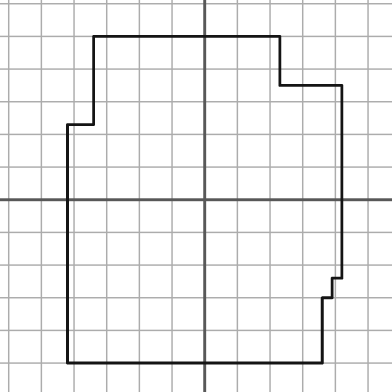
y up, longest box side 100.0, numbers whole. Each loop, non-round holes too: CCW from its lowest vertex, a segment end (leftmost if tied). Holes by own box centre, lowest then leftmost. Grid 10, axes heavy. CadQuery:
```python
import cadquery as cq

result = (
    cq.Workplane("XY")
    .moveTo(-42.0, -50.0)
    .lineTo(36.0, -50.0)
    .lineTo(36.0, -30.0)
    .lineTo(39.0, -30.0)
    .lineTo(39.0, -24.0)
    .lineTo(42.0, -24.0)
    .lineTo(42.0, 35.0)
    .lineTo(23.0, 35.0)
    .lineTo(23.0, 50.0)
    .lineTo(-34.0, 50.0)
    .lineTo(-34.0, 23.0)
    .lineTo(-42.0, 23.0)
    .close()
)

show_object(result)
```